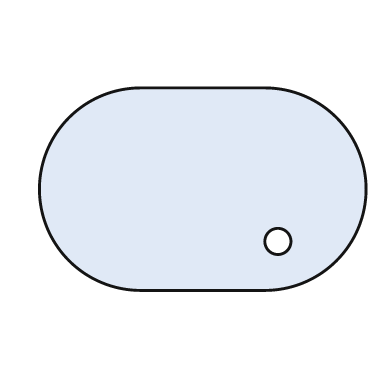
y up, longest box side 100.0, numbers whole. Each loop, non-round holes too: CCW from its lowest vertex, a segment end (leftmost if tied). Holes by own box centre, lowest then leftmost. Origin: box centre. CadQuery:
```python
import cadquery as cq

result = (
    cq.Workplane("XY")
    .moveTo(-19.0, -31.0)
    .lineTo(19.0, -31.0)
    .threePointArc((50.0, 0.0), (19.0, 31.0))
    .lineTo(-19.0, 31.0)
    .threePointArc((-50.0, 0.0), (-19.0, -31.0))
    .close()
    .moveTo(23.0, -16.0)
    .circle(4.0)
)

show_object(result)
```